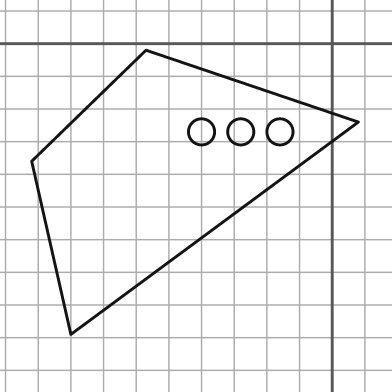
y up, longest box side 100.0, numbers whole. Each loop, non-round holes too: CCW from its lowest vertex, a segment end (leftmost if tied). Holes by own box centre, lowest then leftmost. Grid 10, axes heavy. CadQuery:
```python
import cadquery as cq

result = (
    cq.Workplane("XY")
    .moveTo(-80.0, -89.0)
    .lineTo(8.0, -24.0)
    .lineTo(-57.0, -2.0)
    .lineTo(-92.0, -36.0)
    .close()
    .moveTo(-40.0, -27.0)
    .circle(4.0)
    .moveTo(-28.0, -27.0)
    .circle(4.0)
    .moveTo(-16.0, -27.0)
    .circle(4.0)
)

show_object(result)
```